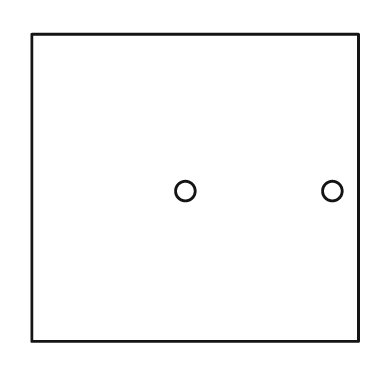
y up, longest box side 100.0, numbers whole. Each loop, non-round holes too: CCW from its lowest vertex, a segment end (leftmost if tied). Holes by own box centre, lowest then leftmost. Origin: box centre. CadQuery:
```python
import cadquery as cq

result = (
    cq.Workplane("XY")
    .moveTo(-50.0, -47.0)
    .lineTo(50.0, -47.0)
    .lineTo(50.0, 47.0)
    .lineTo(-50.0, 47.0)
    .close()
    .moveTo(-3.0, -1.0)
    .circle(3.0)
    .moveTo(42.0, -1.0)
    .circle(3.0)
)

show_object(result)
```